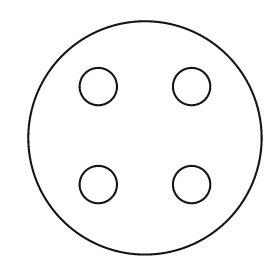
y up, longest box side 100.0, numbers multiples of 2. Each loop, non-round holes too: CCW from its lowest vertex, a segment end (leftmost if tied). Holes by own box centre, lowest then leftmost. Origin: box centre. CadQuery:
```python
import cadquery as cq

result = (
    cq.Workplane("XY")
    .moveTo(0.0, 0.0)
    .circle(50.0)
    .moveTo(-20.0, -20.0)
    .circle(8.0)
    .moveTo(20.0, -20.0)
    .circle(8.0)
    .moveTo(-20.0, 22.0)
    .circle(8.0)
    .moveTo(20.0, 22.0)
    .circle(8.0)
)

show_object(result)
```